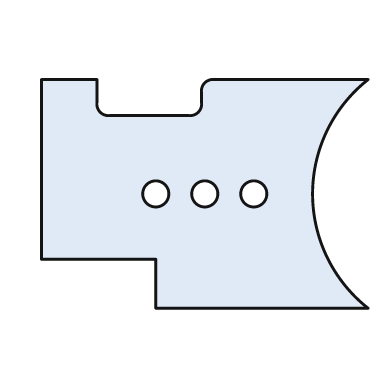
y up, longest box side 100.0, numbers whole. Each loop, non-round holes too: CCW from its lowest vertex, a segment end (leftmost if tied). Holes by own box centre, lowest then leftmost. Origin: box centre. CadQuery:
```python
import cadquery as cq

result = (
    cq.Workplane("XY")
    .moveTo(-15.0, -35.0)
    .lineTo(50.0, -35.0)
    .threePointArc((33.0, 0.0), (50.0, 35.0))
    .lineTo(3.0, 35.0)
    .threePointArc((0.0, 34.0), (-1.0, 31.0))
    .lineTo(-1.0, 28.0)
    .threePointArc((-2.0, 25.0), (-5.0, 24.0))
    .lineTo(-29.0, 24.0)
    .threePointArc((-32.0, 25.0), (-33.0, 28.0))
    .lineTo(-33.0, 35.0)
    .lineTo(-50.0, 35.0)
    .lineTo(-50.0, -20.0)
    .lineTo(-15.0, -20.0)
    .close()
    .moveTo(-15.0, 0.0)
    .circle(4.0)
    .moveTo(0.0, 0.0)
    .circle(4.0)
    .moveTo(15.0, 0.0)
    .circle(4.0)
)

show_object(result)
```